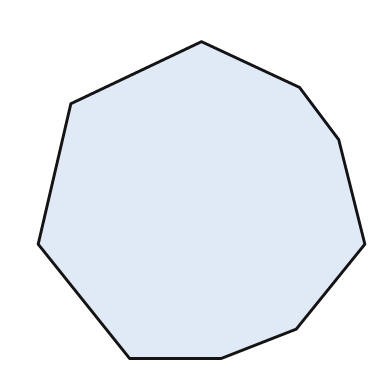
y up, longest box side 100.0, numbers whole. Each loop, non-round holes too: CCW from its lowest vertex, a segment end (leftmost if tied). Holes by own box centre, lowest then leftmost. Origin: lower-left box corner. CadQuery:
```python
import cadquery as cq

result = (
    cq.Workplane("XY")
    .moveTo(28.0, 0.0)
    .lineTo(56.0, 0.0)
    .lineTo(79.0, 9.0)
    .lineTo(100.0, 35.0)
    .lineTo(92.0, 67.0)
    .lineTo(80.0, 83.0)
    .lineTo(50.0, 97.0)
    .lineTo(10.0, 78.0)
    .lineTo(0.0, 35.0)
    .close()
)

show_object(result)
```